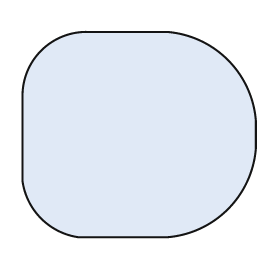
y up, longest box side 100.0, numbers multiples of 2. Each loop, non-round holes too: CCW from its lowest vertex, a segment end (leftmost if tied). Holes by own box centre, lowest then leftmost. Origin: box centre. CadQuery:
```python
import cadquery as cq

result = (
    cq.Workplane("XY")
    .moveTo(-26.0, -44.0)
    .lineTo(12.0, -44.0)
    .threePointArc((38.0, -32.0), (50.0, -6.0))
    .lineTo(50.0, 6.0)
    .threePointArc((38.0, 32.0), (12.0, 44.0))
    .lineTo(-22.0, 44.0)
    .threePointArc((-42.0, 36.0), (-50.0, 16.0))
    .lineTo(-50.0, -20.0)
    .threePointArc((-42.0, -36.0), (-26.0, -44.0))
    .close()
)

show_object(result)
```